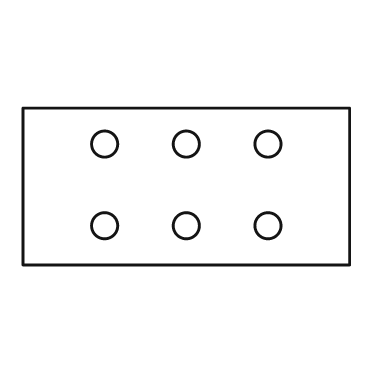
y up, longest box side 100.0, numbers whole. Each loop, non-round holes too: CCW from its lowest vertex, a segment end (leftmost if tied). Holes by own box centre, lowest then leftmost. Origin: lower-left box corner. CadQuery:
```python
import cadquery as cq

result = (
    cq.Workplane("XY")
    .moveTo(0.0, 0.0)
    .lineTo(100.0, 0.0)
    .lineTo(100.0, 48.0)
    .lineTo(0.0, 48.0)
    .close()
    .moveTo(25.0, 12.0)
    .circle(4.0)
    .moveTo(50.0, 12.0)
    .circle(4.0)
    .moveTo(75.0, 12.0)
    .circle(4.0)
    .moveTo(25.0, 37.0)
    .circle(4.0)
    .moveTo(50.0, 37.0)
    .circle(4.0)
    .moveTo(75.0, 37.0)
    .circle(4.0)
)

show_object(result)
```